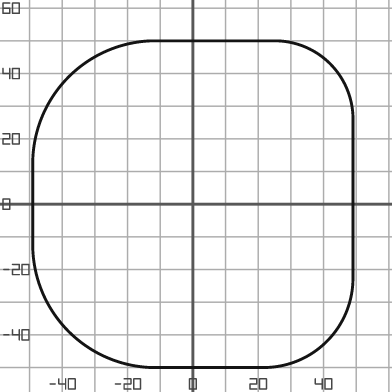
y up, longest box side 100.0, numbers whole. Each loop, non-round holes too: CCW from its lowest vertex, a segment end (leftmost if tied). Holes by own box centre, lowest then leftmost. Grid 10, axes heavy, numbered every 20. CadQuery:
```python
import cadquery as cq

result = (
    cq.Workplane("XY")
    .moveTo(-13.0, -50.0)
    .lineTo(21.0, -50.0)
    .threePointArc((41.0, -42.0), (49.0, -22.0))
    .lineTo(49.0, 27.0)
    .threePointArc((42.0, 43.0), (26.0, 50.0))
    .lineTo(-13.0, 50.0)
    .threePointArc((-38.0, 39.0), (-49.0, 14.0))
    .lineTo(-49.0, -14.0)
    .threePointArc((-38.0, -39.0), (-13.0, -50.0))
    .close()
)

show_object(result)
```